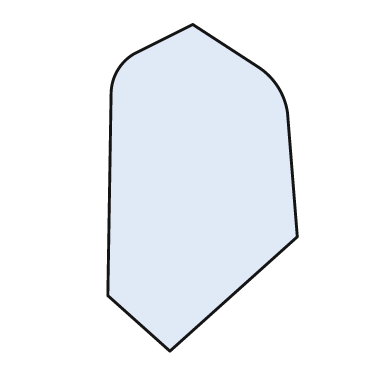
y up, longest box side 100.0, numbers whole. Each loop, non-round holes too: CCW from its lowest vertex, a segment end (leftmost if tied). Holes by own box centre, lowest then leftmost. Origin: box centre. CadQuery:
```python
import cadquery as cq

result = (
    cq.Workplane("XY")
    .moveTo(-10.0, -50.0)
    .lineTo(29.0, -15.0)
    .lineTo(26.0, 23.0)
    .threePointArc((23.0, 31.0), (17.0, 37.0))
    .lineTo(-3.0, 50.0)
    .lineTo(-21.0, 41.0)
    .threePointArc((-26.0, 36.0), (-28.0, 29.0))
    .lineTo(-29.0, -33.0)
    .close()
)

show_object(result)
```